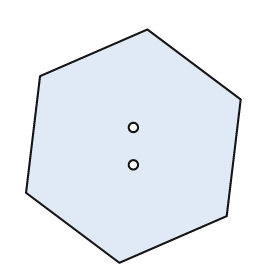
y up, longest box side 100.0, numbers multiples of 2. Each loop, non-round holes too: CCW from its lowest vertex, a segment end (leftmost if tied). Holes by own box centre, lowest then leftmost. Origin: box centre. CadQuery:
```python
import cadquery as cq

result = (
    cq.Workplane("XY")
    .moveTo(-6.0, -50.0)
    .lineTo(40.0, -30.0)
    .lineTo(46.0, 20.0)
    .lineTo(6.0, 50.0)
    .lineTo(-40.0, 30.0)
    .lineTo(-46.0, -20.0)
    .close()
    .moveTo(0.0, -8.0)
    .circle(2.0)
    .moveTo(0.0, 8.0)
    .circle(2.0)
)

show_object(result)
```